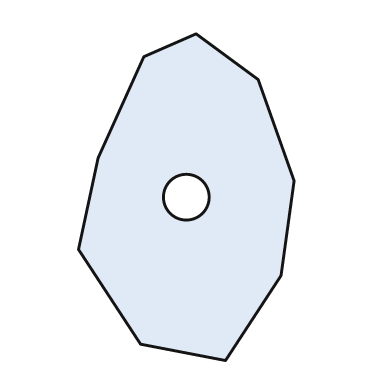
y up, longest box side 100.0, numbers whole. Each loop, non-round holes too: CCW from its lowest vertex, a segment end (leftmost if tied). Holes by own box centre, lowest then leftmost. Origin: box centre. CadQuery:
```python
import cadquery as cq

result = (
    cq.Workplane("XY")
    .moveTo(12.0, -50.0)
    .lineTo(29.0, -24.0)
    .lineTo(33.0, 5.0)
    .lineTo(22.0, 36.0)
    .lineTo(3.0, 50.0)
    .lineTo(-13.0, 43.0)
    .lineTo(-27.0, 12.0)
    .lineTo(-33.0, -16.0)
    .lineTo(-14.0, -45.0)
    .close()
    .moveTo(0.0, 0.0)
    .circle(7.0)
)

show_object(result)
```